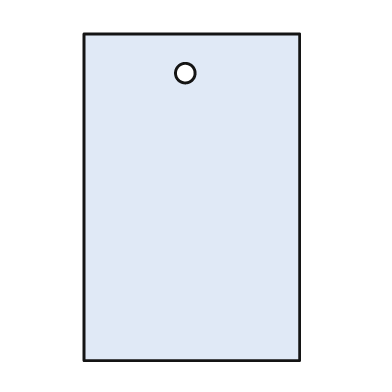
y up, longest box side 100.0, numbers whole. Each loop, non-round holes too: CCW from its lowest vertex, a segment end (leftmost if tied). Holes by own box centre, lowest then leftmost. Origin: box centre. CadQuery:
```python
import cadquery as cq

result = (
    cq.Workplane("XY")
    .moveTo(-33.0, -50.0)
    .lineTo(33.0, -50.0)
    .lineTo(33.0, 50.0)
    .lineTo(-33.0, 50.0)
    .close()
    .moveTo(-2.0, 38.0)
    .circle(3.0)
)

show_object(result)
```